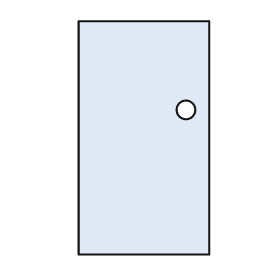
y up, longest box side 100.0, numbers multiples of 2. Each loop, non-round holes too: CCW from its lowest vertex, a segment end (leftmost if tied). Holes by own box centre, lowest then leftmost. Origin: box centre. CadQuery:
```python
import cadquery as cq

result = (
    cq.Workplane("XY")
    .moveTo(-28.0, -50.0)
    .lineTo(28.0, -50.0)
    .lineTo(28.0, 50.0)
    .lineTo(-28.0, 50.0)
    .close()
    .moveTo(18.0, 12.0)
    .circle(4.0)
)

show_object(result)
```